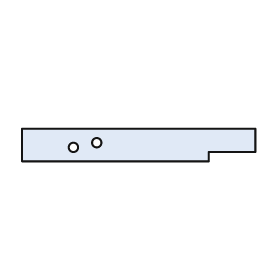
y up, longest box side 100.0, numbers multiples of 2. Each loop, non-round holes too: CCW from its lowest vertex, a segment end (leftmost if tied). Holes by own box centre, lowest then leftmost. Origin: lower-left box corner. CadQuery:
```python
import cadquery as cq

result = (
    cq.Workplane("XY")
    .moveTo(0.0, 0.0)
    .lineTo(80.0, 0.0)
    .lineTo(80.0, 4.0)
    .lineTo(100.0, 4.0)
    .lineTo(100.0, 14.0)
    .lineTo(0.0, 14.0)
    .close()
    .moveTo(22.0, 6.0)
    .circle(2.0)
    .moveTo(32.0, 8.0)
    .circle(2.0)
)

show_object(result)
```